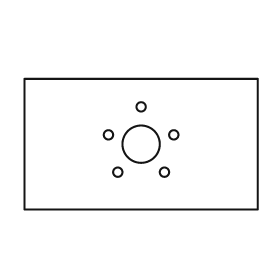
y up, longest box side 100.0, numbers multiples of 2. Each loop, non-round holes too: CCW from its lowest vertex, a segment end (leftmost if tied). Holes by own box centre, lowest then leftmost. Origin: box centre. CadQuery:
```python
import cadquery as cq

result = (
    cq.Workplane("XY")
    .moveTo(-50.0, -28.0)
    .lineTo(50.0, -28.0)
    .lineTo(50.0, 28.0)
    .lineTo(-50.0, 28.0)
    .close()
    .moveTo(-10.0, -12.0)
    .circle(2.0)
    .moveTo(10.0, -12.0)
    .circle(2.0)
    .moveTo(0.0, 0.0)
    .circle(8.0)
    .moveTo(-14.0, 4.0)
    .circle(2.0)
    .moveTo(14.0, 4.0)
    .circle(2.0)
    .moveTo(0.0, 16.0)
    .circle(2.0)
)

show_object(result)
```